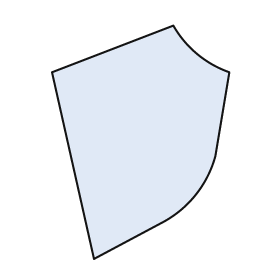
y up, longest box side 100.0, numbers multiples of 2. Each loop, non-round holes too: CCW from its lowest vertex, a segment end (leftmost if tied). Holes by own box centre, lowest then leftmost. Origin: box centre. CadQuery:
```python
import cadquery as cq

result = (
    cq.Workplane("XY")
    .moveTo(-20.0, -50.0)
    .lineTo(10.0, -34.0)
    .threePointArc((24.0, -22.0), (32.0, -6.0))
    .lineTo(38.0, 30.0)
    .threePointArc((24.0, 38.0), (14.0, 50.0))
    .lineTo(-38.0, 30.0)
    .close()
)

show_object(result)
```